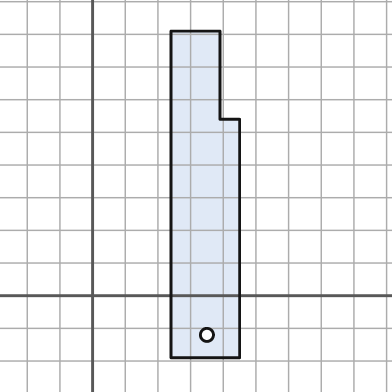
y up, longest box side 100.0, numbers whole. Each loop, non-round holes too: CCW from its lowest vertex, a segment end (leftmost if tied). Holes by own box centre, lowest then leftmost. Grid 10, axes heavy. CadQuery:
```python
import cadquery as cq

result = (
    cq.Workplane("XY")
    .moveTo(24.0, -19.0)
    .lineTo(45.0, -19.0)
    .lineTo(45.0, 54.0)
    .lineTo(39.0, 54.0)
    .lineTo(39.0, 81.0)
    .lineTo(24.0, 81.0)
    .close()
    .moveTo(35.0, -12.0)
    .circle(2.0)
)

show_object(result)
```